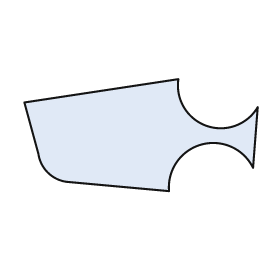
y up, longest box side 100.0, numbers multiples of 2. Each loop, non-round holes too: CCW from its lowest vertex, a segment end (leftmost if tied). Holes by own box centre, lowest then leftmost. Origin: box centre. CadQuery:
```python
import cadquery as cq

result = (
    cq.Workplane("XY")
    .moveTo(12.0, -24.0)
    .threePointArc((26.0, -4.0), (48.0, -14.0))
    .lineTo(50.0, 12.0)
    .threePointArc((28.0, 4.0), (16.0, 24.0))
    .lineTo(-50.0, 14.0)
    .lineTo(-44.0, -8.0)
    .threePointArc((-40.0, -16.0), (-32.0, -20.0))
    .close()
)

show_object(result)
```